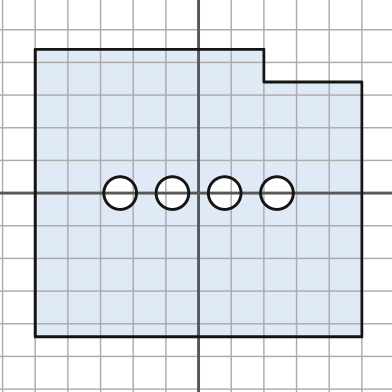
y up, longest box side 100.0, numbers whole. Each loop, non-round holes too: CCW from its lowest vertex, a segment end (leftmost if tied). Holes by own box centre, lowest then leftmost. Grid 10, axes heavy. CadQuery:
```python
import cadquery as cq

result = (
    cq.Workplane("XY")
    .moveTo(-50.0, -44.0)
    .lineTo(50.0, -44.0)
    .lineTo(50.0, 34.0)
    .lineTo(20.0, 34.0)
    .lineTo(20.0, 44.0)
    .lineTo(-50.0, 44.0)
    .close()
    .moveTo(-24.0, 0.0)
    .circle(5.0)
    .moveTo(-8.0, 0.0)
    .circle(5.0)
    .moveTo(8.0, 0.0)
    .circle(5.0)
    .moveTo(24.0, 0.0)
    .circle(5.0)
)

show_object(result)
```